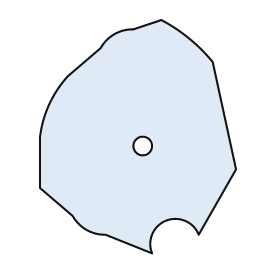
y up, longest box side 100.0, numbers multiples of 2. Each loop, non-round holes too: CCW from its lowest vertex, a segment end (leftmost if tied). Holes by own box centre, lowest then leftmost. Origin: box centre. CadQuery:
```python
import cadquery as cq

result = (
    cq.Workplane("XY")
    .moveTo(6.0, -50.0)
    .threePointArc((12.0, -36.0), (26.0, -42.0))
    .lineTo(42.0, -14.0)
    .lineTo(32.0, 32.0)
    .threePointArc((22.0, 42.0), (10.0, 50.0))
    .lineTo(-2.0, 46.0)
    .threePointArc((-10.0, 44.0), (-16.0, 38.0))
    .lineTo(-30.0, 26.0)
    .threePointArc((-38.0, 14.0), (-42.0, 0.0))
    .lineTo(-42.0, -22.0)
    .lineTo(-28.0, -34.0)
    .threePointArc((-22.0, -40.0), (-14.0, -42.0))
    .close()
    .moveTo(2.0, -4.0)
    .circle(4.0)
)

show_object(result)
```